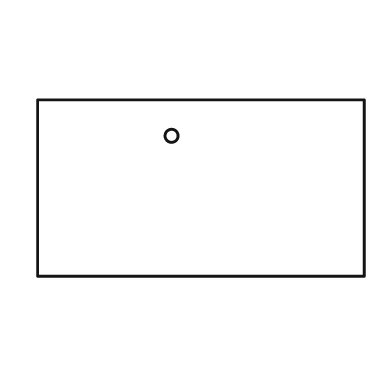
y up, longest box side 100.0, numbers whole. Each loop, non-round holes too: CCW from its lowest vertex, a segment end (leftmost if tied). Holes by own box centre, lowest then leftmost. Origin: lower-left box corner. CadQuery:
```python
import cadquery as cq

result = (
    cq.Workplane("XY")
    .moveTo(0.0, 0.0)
    .lineTo(100.0, 0.0)
    .lineTo(100.0, 54.0)
    .lineTo(0.0, 54.0)
    .close()
    .moveTo(41.0, 43.0)
    .circle(2.0)
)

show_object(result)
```